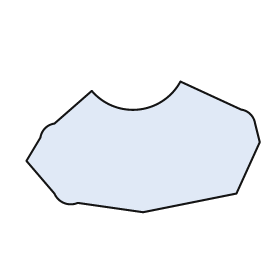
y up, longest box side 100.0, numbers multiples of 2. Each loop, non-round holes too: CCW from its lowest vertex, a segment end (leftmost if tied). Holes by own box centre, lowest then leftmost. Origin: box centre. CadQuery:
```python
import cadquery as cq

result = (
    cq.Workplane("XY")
    .moveTo(0.0, -28.0)
    .lineTo(40.0, -20.0)
    .lineTo(50.0, 2.0)
    .lineTo(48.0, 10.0)
    .threePointArc((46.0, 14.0), (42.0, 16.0))
    .lineTo(16.0, 28.0)
    .threePointArc((-2.0, 16.0), (-22.0, 24.0))
    .lineTo(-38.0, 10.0)
    .threePointArc((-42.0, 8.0), (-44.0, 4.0))
    .lineTo(-50.0, -6.0)
    .lineTo(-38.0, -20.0)
    .threePointArc((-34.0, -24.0), (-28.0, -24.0))
    .close()
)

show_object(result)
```